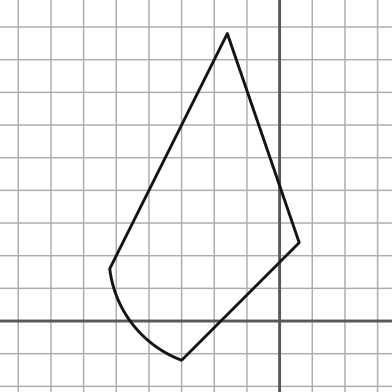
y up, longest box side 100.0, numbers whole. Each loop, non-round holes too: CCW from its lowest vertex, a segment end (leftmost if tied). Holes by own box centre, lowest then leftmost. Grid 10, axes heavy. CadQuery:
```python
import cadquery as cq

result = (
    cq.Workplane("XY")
    .moveTo(-30.0, -12.0)
    .lineTo(6.0, 24.0)
    .lineTo(-16.0, 88.0)
    .lineTo(-52.0, 16.0)
    .threePointArc((-45.0, -1.0), (-30.0, -12.0))
    .close()
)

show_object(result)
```